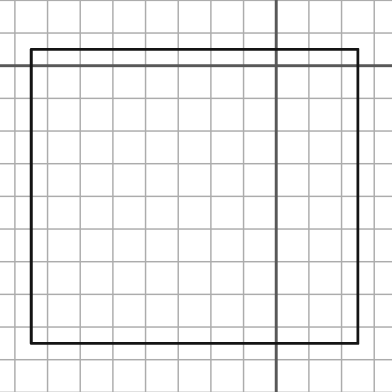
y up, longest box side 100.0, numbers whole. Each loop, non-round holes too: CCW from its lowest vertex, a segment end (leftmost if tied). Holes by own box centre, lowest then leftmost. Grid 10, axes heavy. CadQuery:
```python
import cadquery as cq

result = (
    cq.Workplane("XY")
    .moveTo(-75.0, -85.0)
    .lineTo(25.0, -85.0)
    .lineTo(25.0, 5.0)
    .lineTo(-75.0, 5.0)
    .close()
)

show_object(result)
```